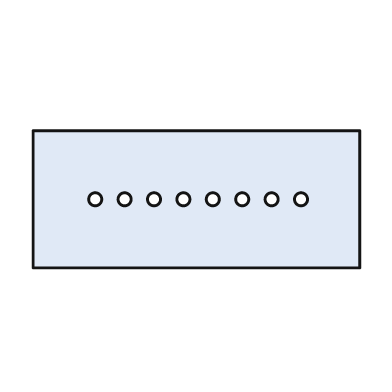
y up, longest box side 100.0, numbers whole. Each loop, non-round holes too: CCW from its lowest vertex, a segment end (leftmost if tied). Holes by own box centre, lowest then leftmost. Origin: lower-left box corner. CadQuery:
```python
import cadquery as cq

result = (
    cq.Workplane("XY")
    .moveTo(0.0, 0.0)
    .lineTo(100.0, 0.0)
    .lineTo(100.0, 42.0)
    .lineTo(0.0, 42.0)
    .close()
    .moveTo(19.0, 21.0)
    .circle(2.0)
    .moveTo(28.0, 21.0)
    .circle(2.0)
    .moveTo(37.0, 21.0)
    .circle(2.0)
    .moveTo(46.0, 21.0)
    .circle(2.0)
    .moveTo(55.0, 21.0)
    .circle(2.0)
    .moveTo(64.0, 21.0)
    .circle(2.0)
    .moveTo(73.0, 21.0)
    .circle(2.0)
    .moveTo(82.0, 21.0)
    .circle(2.0)
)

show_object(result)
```